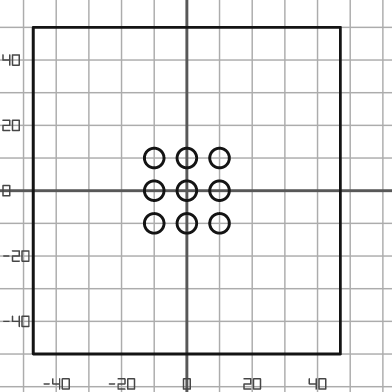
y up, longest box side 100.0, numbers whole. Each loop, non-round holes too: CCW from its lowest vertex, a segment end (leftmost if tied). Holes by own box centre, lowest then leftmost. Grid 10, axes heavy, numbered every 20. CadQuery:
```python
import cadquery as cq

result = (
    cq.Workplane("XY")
    .moveTo(-47.0, -50.0)
    .lineTo(47.0, -50.0)
    .lineTo(47.0, 50.0)
    .lineTo(-47.0, 50.0)
    .close()
    .moveTo(-10.0, -10.0)
    .circle(3.0)
    .moveTo(0.0, -10.0)
    .circle(3.0)
    .moveTo(10.0, -10.0)
    .circle(3.0)
    .moveTo(-10.0, 0.0)
    .circle(3.0)
    .moveTo(0.0, 0.0)
    .circle(3.0)
    .moveTo(10.0, 0.0)
    .circle(3.0)
    .moveTo(-10.0, 10.0)
    .circle(3.0)
    .moveTo(0.0, 10.0)
    .circle(3.0)
    .moveTo(10.0, 10.0)
    .circle(3.0)
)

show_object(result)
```